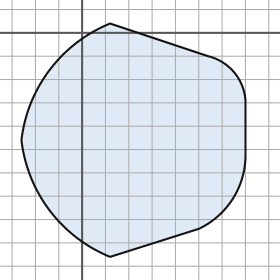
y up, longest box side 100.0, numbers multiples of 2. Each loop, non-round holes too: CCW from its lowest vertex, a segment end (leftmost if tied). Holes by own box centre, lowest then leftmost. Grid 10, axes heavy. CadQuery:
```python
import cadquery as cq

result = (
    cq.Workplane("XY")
    .moveTo(12.0, -96.0)
    .lineTo(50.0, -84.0)
    .threePointArc((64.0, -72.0), (70.0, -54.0))
    .lineTo(70.0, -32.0)
    .threePointArc((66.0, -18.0), (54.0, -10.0))
    .lineTo(12.0, 4.0)
    .threePointArc((-14.0, -16.0), (-26.0, -46.0))
    .threePointArc((-14.0, -76.0), (12.0, -96.0))
    .close()
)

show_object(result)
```